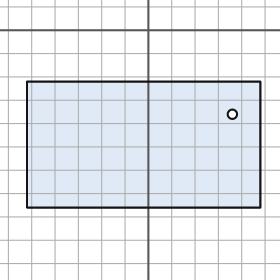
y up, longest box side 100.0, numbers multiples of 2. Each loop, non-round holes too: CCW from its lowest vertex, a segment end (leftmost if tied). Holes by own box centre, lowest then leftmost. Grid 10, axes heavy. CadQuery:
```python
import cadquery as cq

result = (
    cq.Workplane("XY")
    .moveTo(-52.0, -76.0)
    .lineTo(48.0, -76.0)
    .lineTo(48.0, -22.0)
    .lineTo(-52.0, -22.0)
    .close()
    .moveTo(36.0, -36.0)
    .circle(2.0)
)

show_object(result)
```